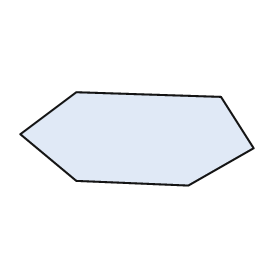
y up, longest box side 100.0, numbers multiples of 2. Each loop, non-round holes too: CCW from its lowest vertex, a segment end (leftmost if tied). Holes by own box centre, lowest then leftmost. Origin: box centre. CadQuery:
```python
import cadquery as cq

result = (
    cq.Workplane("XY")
    .moveTo(22.0, -20.0)
    .lineTo(50.0, -4.0)
    .lineTo(36.0, 18.0)
    .lineTo(-26.0, 20.0)
    .lineTo(-50.0, 2.0)
    .lineTo(-26.0, -18.0)
    .close()
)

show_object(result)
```